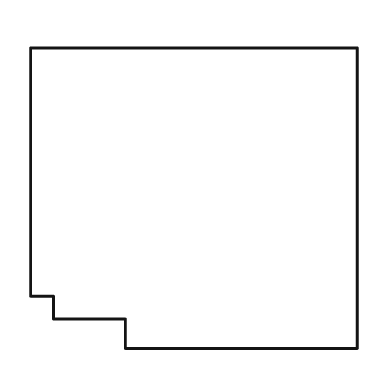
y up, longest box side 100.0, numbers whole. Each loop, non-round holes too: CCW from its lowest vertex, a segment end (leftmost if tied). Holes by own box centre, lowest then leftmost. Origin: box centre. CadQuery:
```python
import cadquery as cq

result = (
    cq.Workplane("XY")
    .moveTo(-21.0, -46.0)
    .lineTo(50.0, -46.0)
    .lineTo(50.0, 46.0)
    .lineTo(-50.0, 46.0)
    .lineTo(-50.0, -30.0)
    .lineTo(-43.0, -30.0)
    .lineTo(-43.0, -37.0)
    .lineTo(-21.0, -37.0)
    .close()
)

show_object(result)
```